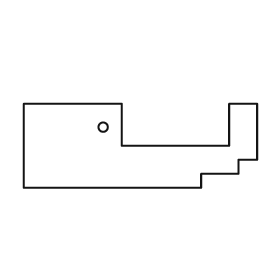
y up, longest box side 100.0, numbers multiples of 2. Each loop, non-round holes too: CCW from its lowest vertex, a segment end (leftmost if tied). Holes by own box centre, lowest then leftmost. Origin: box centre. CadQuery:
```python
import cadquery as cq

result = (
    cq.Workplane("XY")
    .moveTo(-50.0, -18.0)
    .lineTo(26.0, -18.0)
    .lineTo(26.0, -12.0)
    .lineTo(42.0, -12.0)
    .lineTo(42.0, -6.0)
    .lineTo(50.0, -6.0)
    .lineTo(50.0, 18.0)
    .lineTo(38.0, 18.0)
    .lineTo(38.0, 0.0)
    .lineTo(-8.0, 0.0)
    .lineTo(-8.0, 18.0)
    .lineTo(-50.0, 18.0)
    .close()
    .moveTo(-16.0, 8.0)
    .circle(2.0)
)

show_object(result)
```